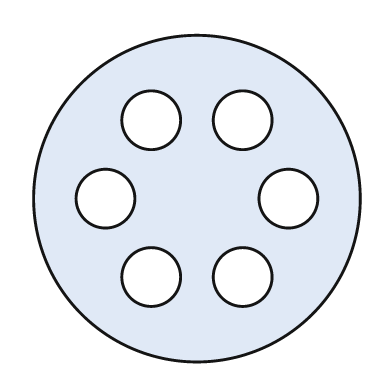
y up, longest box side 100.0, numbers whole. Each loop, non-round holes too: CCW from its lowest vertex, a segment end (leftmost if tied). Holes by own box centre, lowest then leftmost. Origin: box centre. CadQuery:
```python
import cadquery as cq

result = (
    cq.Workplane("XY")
    .moveTo(0.0, 0.0)
    .circle(50.0)
    .moveTo(-14.0, -24.0)
    .circle(9.0)
    .moveTo(14.0, -24.0)
    .circle(9.0)
    .moveTo(-28.0, 0.0)
    .circle(9.0)
    .moveTo(28.0, 0.0)
    .circle(9.0)
    .moveTo(-14.0, 24.0)
    .circle(9.0)
    .moveTo(14.0, 24.0)
    .circle(9.0)
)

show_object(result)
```